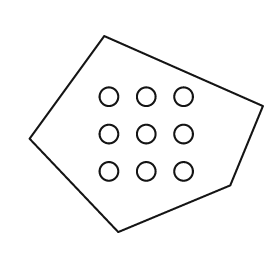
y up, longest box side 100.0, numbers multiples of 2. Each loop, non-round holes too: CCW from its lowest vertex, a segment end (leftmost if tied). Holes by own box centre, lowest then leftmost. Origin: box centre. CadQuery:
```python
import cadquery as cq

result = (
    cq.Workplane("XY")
    .moveTo(-12.0, -42.0)
    .lineTo(36.0, -22.0)
    .lineTo(50.0, 12.0)
    .lineTo(-18.0, 42.0)
    .lineTo(-50.0, -2.0)
    .close()
    .moveTo(-16.0, -16.0)
    .circle(4.0)
    .moveTo(0.0, -16.0)
    .circle(4.0)
    .moveTo(16.0, -16.0)
    .circle(4.0)
    .moveTo(-16.0, 0.0)
    .circle(4.0)
    .moveTo(0.0, 0.0)
    .circle(4.0)
    .moveTo(16.0, 0.0)
    .circle(4.0)
    .moveTo(-16.0, 16.0)
    .circle(4.0)
    .moveTo(0.0, 16.0)
    .circle(4.0)
    .moveTo(16.0, 16.0)
    .circle(4.0)
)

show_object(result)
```